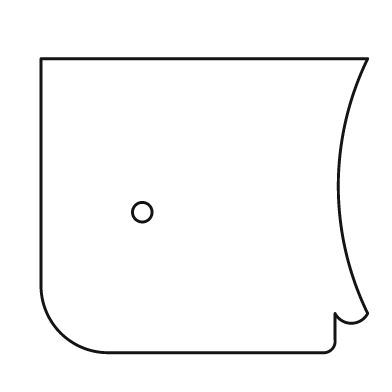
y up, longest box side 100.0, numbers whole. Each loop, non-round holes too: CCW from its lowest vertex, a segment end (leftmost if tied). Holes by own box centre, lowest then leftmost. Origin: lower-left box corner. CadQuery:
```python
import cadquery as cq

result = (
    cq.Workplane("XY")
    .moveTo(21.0, 0.0)
    .lineTo(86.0, 0.0)
    .threePointArc((89.0, 1.0), (90.0, 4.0))
    .lineTo(90.0, 12.0)
    .threePointArc((95.0, 9.0), (100.0, 12.0))
    .threePointArc((91.0, 51.0), (100.0, 90.0))
    .lineTo(0.0, 90.0)
    .lineTo(0.0, 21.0)
    .threePointArc((6.0, 6.0), (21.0, 0.0))
    .close()
    .moveTo(31.0, 43.0)
    .circle(3.0)
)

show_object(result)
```